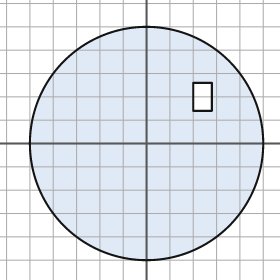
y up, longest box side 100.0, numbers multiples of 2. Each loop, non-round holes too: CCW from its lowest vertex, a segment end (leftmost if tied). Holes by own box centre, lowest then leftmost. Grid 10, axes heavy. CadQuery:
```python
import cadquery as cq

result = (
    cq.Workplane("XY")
    .moveTo(0.0, 0.0)
    .circle(50.0)
    .moveTo(20.0, 14.0)
    .lineTo(28.0, 14.0)
    .lineTo(28.0, 26.0)
    .lineTo(20.0, 26.0)
    .close()
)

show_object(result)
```